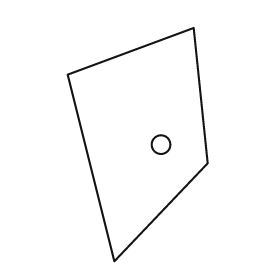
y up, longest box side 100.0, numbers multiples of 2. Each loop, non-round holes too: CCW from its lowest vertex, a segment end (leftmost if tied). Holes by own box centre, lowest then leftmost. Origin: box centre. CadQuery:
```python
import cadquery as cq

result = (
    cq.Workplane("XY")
    .moveTo(-10.0, -50.0)
    .lineTo(30.0, -8.0)
    .lineTo(24.0, 50.0)
    .lineTo(-30.0, 30.0)
    .close()
    .moveTo(10.0, 0.0)
    .circle(4.0)
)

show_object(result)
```